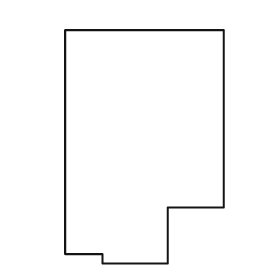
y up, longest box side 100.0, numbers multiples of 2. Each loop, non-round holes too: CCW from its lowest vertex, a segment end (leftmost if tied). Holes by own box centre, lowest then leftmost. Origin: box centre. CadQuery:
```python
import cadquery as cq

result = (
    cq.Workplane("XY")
    .moveTo(-18.0, -50.0)
    .lineTo(10.0, -50.0)
    .lineTo(10.0, -26.0)
    .lineTo(34.0, -26.0)
    .lineTo(34.0, 50.0)
    .lineTo(-34.0, 50.0)
    .lineTo(-34.0, -46.0)
    .lineTo(-18.0, -46.0)
    .close()
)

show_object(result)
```